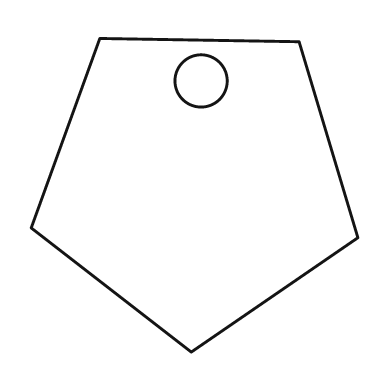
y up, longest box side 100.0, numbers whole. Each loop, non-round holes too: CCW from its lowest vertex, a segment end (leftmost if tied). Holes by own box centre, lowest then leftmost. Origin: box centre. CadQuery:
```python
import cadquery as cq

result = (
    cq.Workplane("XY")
    .moveTo(-1.0, -48.0)
    .lineTo(50.0, -13.0)
    .lineTo(32.0, 47.0)
    .lineTo(-29.0, 48.0)
    .lineTo(-50.0, -10.0)
    .close()
    .moveTo(2.0, 35.0)
    .circle(8.0)
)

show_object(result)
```